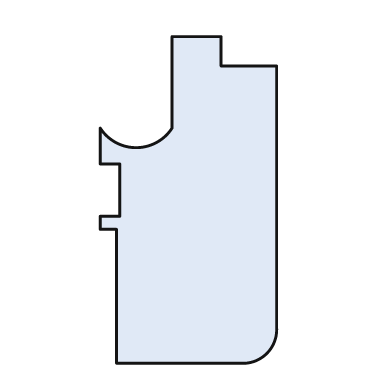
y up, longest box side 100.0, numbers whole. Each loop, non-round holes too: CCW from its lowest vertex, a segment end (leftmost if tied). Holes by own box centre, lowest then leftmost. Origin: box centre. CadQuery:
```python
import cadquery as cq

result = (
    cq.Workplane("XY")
    .moveTo(-22.0, -50.0)
    .lineTo(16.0, -50.0)
    .threePointArc((24.0, -47.0), (27.0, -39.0))
    .lineTo(27.0, 41.0)
    .lineTo(10.0, 41.0)
    .lineTo(10.0, 50.0)
    .lineTo(-5.0, 50.0)
    .lineTo(-5.0, 22.0)
    .threePointArc((-16.0, 16.0), (-27.0, 22.0))
    .lineTo(-27.0, 11.0)
    .lineTo(-21.0, 11.0)
    .lineTo(-21.0, -5.0)
    .lineTo(-27.0, -5.0)
    .lineTo(-27.0, -9.0)
    .lineTo(-22.0, -9.0)
    .close()
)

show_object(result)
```